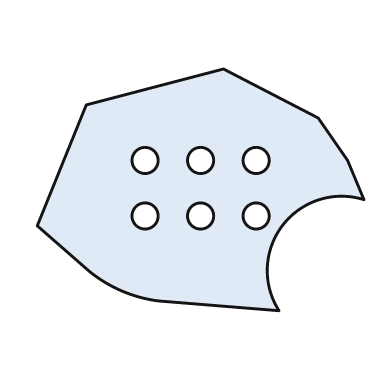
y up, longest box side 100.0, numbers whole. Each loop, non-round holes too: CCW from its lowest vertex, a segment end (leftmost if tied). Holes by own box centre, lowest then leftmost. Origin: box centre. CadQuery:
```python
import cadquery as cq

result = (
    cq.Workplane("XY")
    .moveTo(24.0, -37.0)
    .threePointArc((25.0, -11.0), (50.0, -3.0))
    .lineTo(45.0, 9.0)
    .lineTo(36.0, 22.0)
    .lineTo(7.0, 37.0)
    .lineTo(-35.0, 26.0)
    .lineTo(-50.0, -11.0)
    .lineTo(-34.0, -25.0)
    .threePointArc((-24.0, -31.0), (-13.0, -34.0))
    .close()
    .moveTo(-17.0, -8.0)
    .circle(4.0)
    .moveTo(0.0, -8.0)
    .circle(4.0)
    .moveTo(17.0, -8.0)
    .circle(4.0)
    .moveTo(-17.0, 9.0)
    .circle(4.0)
    .moveTo(0.0, 9.0)
    .circle(4.0)
    .moveTo(17.0, 9.0)
    .circle(4.0)
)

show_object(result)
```